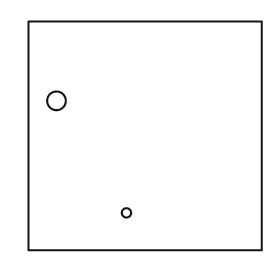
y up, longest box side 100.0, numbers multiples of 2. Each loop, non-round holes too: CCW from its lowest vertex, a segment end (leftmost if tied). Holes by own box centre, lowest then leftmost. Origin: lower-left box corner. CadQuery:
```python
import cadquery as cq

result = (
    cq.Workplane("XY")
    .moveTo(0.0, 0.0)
    .lineTo(100.0, 0.0)
    .lineTo(100.0, 98.0)
    .lineTo(0.0, 98.0)
    .close()
    .moveTo(42.0, 16.0)
    .circle(2.0)
    .moveTo(12.0, 64.0)
    .circle(4.0)
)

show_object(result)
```